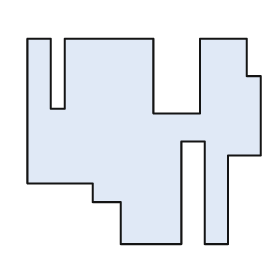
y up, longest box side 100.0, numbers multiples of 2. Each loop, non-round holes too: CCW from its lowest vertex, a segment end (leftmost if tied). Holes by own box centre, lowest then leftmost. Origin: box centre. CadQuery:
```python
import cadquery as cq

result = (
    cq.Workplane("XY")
    .moveTo(-10.0, -44.0)
    .lineTo(16.0, -44.0)
    .lineTo(16.0, 0.0)
    .lineTo(26.0, 0.0)
    .lineTo(26.0, -44.0)
    .lineTo(36.0, -44.0)
    .lineTo(36.0, -6.0)
    .lineTo(50.0, -6.0)
    .lineTo(50.0, 28.0)
    .lineTo(44.0, 28.0)
    .lineTo(44.0, 44.0)
    .lineTo(24.0, 44.0)
    .lineTo(24.0, 12.0)
    .lineTo(4.0, 12.0)
    .lineTo(4.0, 44.0)
    .lineTo(-34.0, 44.0)
    .lineTo(-34.0, 14.0)
    .lineTo(-40.0, 14.0)
    .lineTo(-40.0, 44.0)
    .lineTo(-50.0, 44.0)
    .lineTo(-50.0, -18.0)
    .lineTo(-22.0, -18.0)
    .lineTo(-22.0, -26.0)
    .lineTo(-10.0, -26.0)
    .close()
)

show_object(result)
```